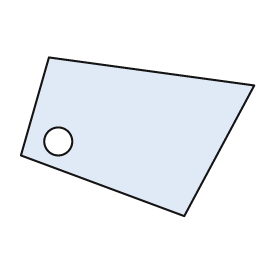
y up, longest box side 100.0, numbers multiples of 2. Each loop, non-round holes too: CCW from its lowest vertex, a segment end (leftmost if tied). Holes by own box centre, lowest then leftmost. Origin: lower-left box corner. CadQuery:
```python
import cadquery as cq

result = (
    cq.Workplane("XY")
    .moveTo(70.0, 0.0)
    .lineTo(100.0, 56.0)
    .lineTo(12.0, 68.0)
    .lineTo(0.0, 26.0)
    .close()
    .moveTo(16.0, 32.0)
    .circle(6.0)
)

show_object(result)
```